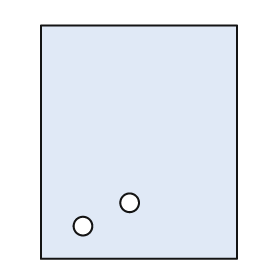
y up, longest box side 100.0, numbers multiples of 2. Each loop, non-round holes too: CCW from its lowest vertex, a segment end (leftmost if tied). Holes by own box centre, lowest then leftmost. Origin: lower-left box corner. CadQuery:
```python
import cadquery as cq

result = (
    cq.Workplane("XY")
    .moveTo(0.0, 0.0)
    .lineTo(84.0, 0.0)
    .lineTo(84.0, 100.0)
    .lineTo(0.0, 100.0)
    .close()
    .moveTo(18.0, 14.0)
    .circle(4.0)
    .moveTo(38.0, 24.0)
    .circle(4.0)
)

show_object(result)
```